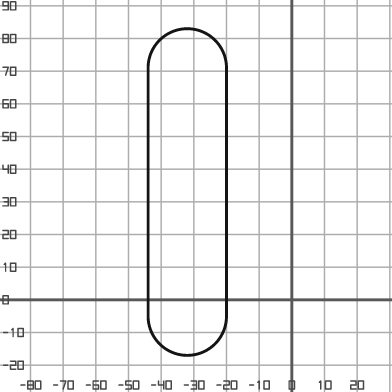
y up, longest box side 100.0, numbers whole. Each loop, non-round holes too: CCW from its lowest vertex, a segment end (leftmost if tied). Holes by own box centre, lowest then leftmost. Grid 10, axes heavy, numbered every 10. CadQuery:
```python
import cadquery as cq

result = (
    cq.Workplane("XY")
    .moveTo(-44.0, -5.0)
    .threePointArc((-32.0, -17.0), (-20.0, -5.0))
    .lineTo(-20.0, 71.0)
    .threePointArc((-32.0, 83.0), (-44.0, 71.0))
    .close()
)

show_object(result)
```